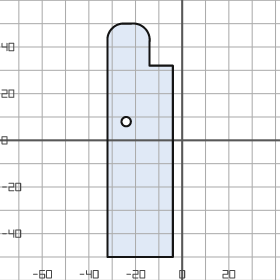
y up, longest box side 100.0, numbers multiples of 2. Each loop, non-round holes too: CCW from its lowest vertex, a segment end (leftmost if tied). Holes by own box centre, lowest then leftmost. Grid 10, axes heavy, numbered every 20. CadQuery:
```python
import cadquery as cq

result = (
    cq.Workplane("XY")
    .moveTo(-32.0, -50.0)
    .lineTo(-4.0, -50.0)
    .lineTo(-4.0, 32.0)
    .lineTo(-14.0, 32.0)
    .lineTo(-14.0, 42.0)
    .threePointArc((-16.0, 48.0), (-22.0, 50.0))
    .lineTo(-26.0, 50.0)
    .threePointArc((-30.0, 48.0), (-32.0, 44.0))
    .close()
    .moveTo(-24.0, 8.0)
    .circle(2.0)
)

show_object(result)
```